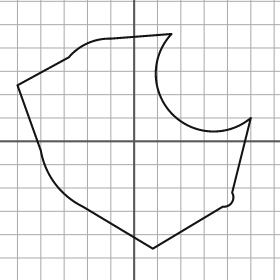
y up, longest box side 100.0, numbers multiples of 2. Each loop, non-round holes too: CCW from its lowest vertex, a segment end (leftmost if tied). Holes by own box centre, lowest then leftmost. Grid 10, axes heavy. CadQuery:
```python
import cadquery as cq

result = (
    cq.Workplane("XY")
    .moveTo(8.0, -46.0)
    .lineTo(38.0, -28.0)
    .threePointArc((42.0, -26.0), (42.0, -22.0))
    .lineTo(50.0, 10.0)
    .threePointArc((16.0, 12.0), (16.0, 46.0))
    .lineTo(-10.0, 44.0)
    .threePointArc((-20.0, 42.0), (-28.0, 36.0))
    .lineTo(-50.0, 24.0)
    .lineTo(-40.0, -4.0)
    .threePointArc((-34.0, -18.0), (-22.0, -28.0))
    .close()
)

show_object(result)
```